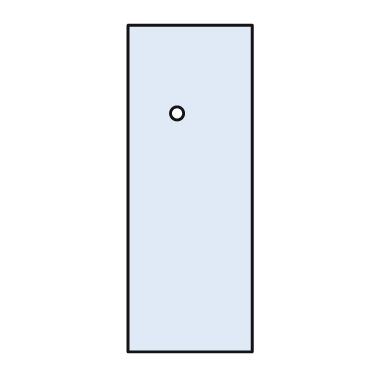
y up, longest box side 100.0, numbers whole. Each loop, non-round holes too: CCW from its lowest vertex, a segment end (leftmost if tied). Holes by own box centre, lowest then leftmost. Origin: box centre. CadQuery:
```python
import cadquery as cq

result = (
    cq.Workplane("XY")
    .moveTo(-19.0, -50.0)
    .lineTo(19.0, -50.0)
    .lineTo(19.0, 50.0)
    .lineTo(-19.0, 50.0)
    .close()
    .moveTo(-4.0, 23.0)
    .circle(2.0)
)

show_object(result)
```